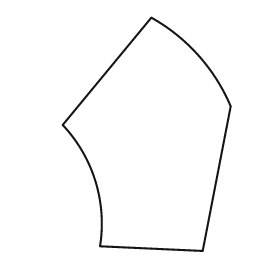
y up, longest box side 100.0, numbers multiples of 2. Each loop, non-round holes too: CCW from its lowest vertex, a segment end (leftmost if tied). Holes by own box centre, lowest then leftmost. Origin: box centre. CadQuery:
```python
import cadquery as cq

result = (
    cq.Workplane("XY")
    .moveTo(24.0, -50.0)
    .lineTo(36.0, 12.0)
    .threePointArc((22.0, 34.0), (2.0, 50.0))
    .lineTo(-36.0, 4.0)
    .threePointArc((-22.0, -20.0), (-20.0, -48.0))
    .close()
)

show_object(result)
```